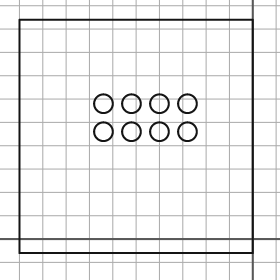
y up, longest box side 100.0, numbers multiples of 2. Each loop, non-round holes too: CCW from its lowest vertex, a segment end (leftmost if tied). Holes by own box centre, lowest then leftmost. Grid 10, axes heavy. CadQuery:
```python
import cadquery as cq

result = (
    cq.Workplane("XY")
    .moveTo(-100.0, -6.0)
    .lineTo(0.0, -6.0)
    .lineTo(0.0, 94.0)
    .lineTo(-100.0, 94.0)
    .close()
    .moveTo(-64.0, 46.0)
    .circle(4.0)
    .moveTo(-52.0, 46.0)
    .circle(4.0)
    .moveTo(-40.0, 46.0)
    .circle(4.0)
    .moveTo(-28.0, 46.0)
    .circle(4.0)
    .moveTo(-64.0, 58.0)
    .circle(4.0)
    .moveTo(-52.0, 58.0)
    .circle(4.0)
    .moveTo(-40.0, 58.0)
    .circle(4.0)
    .moveTo(-28.0, 58.0)
    .circle(4.0)
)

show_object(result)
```